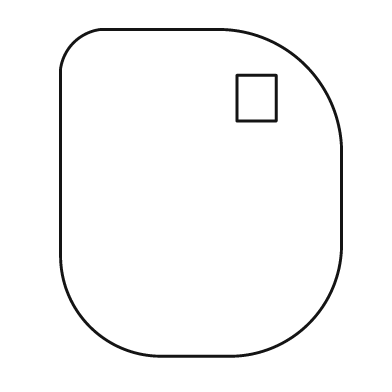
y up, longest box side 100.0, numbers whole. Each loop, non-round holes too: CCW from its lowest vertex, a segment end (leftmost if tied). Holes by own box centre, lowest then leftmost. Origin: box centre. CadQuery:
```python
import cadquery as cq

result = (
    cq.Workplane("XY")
    .moveTo(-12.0, -50.0)
    .lineTo(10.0, -50.0)
    .threePointArc((33.0, -40.0), (43.0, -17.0))
    .lineTo(43.0, 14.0)
    .threePointArc((32.0, 39.0), (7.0, 50.0))
    .lineTo(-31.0, 50.0)
    .threePointArc((-39.0, 46.0), (-43.0, 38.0))
    .lineTo(-43.0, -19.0)
    .threePointArc((-34.0, -41.0), (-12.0, -50.0))
    .close()
    .moveTo(11.0, 22.0)
    .lineTo(23.0, 22.0)
    .lineTo(23.0, 36.0)
    .lineTo(11.0, 36.0)
    .close()
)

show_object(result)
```